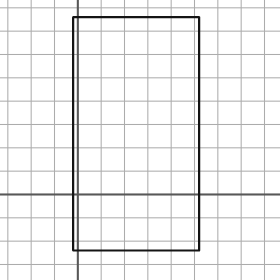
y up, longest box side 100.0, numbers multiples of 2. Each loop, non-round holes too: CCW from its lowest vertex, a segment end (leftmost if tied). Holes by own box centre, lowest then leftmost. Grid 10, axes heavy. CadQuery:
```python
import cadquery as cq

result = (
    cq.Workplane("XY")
    .moveTo(-2.0, -24.0)
    .lineTo(52.0, -24.0)
    .lineTo(52.0, 76.0)
    .lineTo(-2.0, 76.0)
    .close()
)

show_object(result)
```